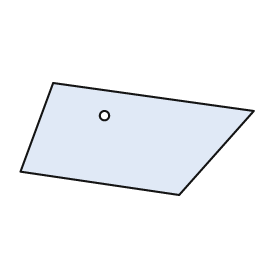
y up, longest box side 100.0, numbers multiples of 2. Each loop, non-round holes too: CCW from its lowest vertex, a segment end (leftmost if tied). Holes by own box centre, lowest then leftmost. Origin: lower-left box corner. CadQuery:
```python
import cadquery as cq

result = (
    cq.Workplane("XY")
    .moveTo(68.0, 0.0)
    .lineTo(100.0, 36.0)
    .lineTo(14.0, 48.0)
    .lineTo(0.0, 10.0)
    .close()
    .moveTo(36.0, 34.0)
    .circle(2.0)
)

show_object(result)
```